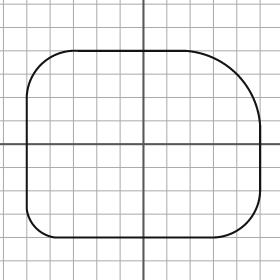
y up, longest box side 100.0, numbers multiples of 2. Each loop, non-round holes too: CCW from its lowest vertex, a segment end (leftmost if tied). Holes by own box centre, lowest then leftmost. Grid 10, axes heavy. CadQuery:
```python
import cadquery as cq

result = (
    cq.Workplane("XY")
    .moveTo(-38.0, -40.0)
    .lineTo(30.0, -40.0)
    .threePointArc((44.0, -34.0), (50.0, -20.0))
    .lineTo(50.0, 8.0)
    .threePointArc((40.0, 30.0), (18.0, 40.0))
    .lineTo(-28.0, 40.0)
    .threePointArc((-44.0, 34.0), (-50.0, 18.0))
    .lineTo(-50.0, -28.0)
    .threePointArc((-46.0, -36.0), (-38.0, -40.0))
    .close()
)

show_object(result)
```